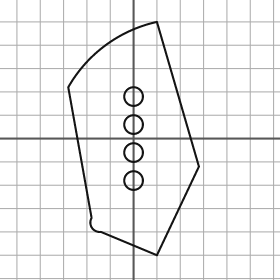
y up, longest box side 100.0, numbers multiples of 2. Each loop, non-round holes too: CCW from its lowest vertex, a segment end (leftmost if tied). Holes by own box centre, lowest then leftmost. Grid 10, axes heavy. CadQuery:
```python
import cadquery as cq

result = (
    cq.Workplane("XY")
    .moveTo(10.0, -50.0)
    .lineTo(28.0, -12.0)
    .lineTo(10.0, 50.0)
    .threePointArc((-12.0, 40.0), (-28.0, 22.0))
    .lineTo(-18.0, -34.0)
    .threePointArc((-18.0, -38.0), (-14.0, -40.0))
    .close()
    .moveTo(0.0, -18.0)
    .circle(4.0)
    .moveTo(0.0, -6.0)
    .circle(4.0)
    .moveTo(0.0, 6.0)
    .circle(4.0)
    .moveTo(0.0, 18.0)
    .circle(4.0)
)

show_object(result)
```